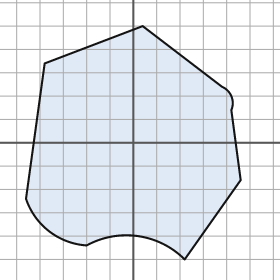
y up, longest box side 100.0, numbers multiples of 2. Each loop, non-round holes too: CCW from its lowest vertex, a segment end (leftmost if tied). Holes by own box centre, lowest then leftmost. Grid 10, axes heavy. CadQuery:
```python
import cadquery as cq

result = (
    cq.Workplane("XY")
    .moveTo(22.0, -50.0)
    .lineTo(46.0, -16.0)
    .lineTo(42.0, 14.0)
    .threePointArc((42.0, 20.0), (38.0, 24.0))
    .lineTo(4.0, 50.0)
    .lineTo(-38.0, 34.0)
    .lineTo(-46.0, -24.0)
    .threePointArc((-36.0, -38.0), (-20.0, -44.0))
    .threePointArc((2.0, -40.0), (22.0, -50.0))
    .close()
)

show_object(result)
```